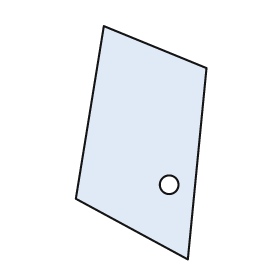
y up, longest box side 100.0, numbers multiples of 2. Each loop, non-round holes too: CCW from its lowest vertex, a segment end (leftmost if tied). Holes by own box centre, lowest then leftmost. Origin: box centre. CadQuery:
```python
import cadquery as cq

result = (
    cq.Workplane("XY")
    .moveTo(20.0, -50.0)
    .lineTo(28.0, 32.0)
    .lineTo(-16.0, 50.0)
    .lineTo(-28.0, -24.0)
    .close()
    .moveTo(12.0, -18.0)
    .circle(4.0)
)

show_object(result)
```